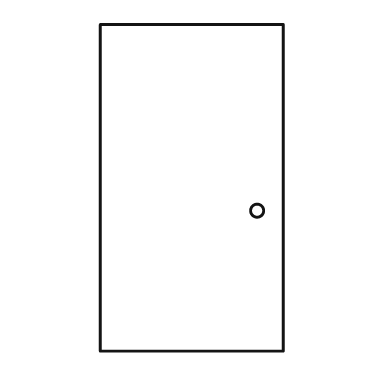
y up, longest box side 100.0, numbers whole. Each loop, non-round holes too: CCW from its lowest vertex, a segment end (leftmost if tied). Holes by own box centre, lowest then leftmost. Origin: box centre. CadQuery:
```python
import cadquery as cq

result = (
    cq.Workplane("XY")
    .moveTo(-28.0, -50.0)
    .lineTo(28.0, -50.0)
    .lineTo(28.0, 50.0)
    .lineTo(-28.0, 50.0)
    .close()
    .moveTo(20.0, -7.0)
    .circle(2.0)
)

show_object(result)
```